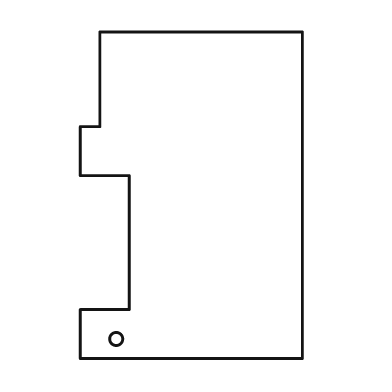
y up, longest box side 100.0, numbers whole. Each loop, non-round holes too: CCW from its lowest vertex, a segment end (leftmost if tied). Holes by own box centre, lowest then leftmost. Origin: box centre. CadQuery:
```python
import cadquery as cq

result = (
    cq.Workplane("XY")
    .moveTo(-34.0, -50.0)
    .lineTo(34.0, -50.0)
    .lineTo(34.0, 50.0)
    .lineTo(-28.0, 50.0)
    .lineTo(-28.0, 21.0)
    .lineTo(-34.0, 21.0)
    .lineTo(-34.0, 6.0)
    .lineTo(-19.0, 6.0)
    .lineTo(-19.0, -35.0)
    .lineTo(-34.0, -35.0)
    .close()
    .moveTo(-23.0, -44.0)
    .circle(2.0)
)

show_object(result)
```